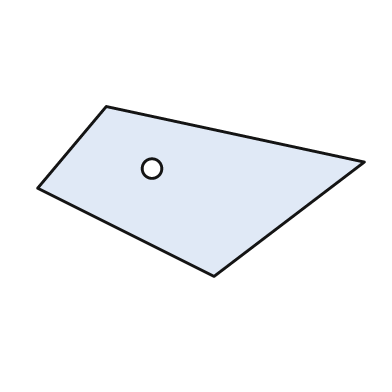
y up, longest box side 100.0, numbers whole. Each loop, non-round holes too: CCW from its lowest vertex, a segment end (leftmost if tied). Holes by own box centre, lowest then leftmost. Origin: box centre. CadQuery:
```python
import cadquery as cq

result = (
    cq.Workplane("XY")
    .moveTo(4.0, -26.0)
    .lineTo(50.0, 9.0)
    .lineTo(-29.0, 26.0)
    .lineTo(-50.0, 1.0)
    .close()
    .moveTo(-15.0, 7.0)
    .circle(3.0)
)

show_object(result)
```